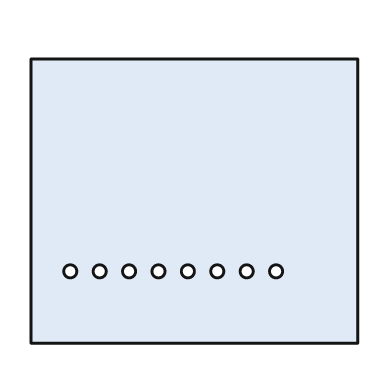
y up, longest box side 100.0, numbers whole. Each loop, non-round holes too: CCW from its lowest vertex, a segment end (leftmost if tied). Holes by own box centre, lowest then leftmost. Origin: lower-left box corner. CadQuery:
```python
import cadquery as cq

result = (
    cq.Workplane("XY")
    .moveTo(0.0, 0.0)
    .lineTo(100.0, 0.0)
    .lineTo(100.0, 87.0)
    .lineTo(0.0, 87.0)
    .close()
    .moveTo(12.0, 22.0)
    .circle(2.0)
    .moveTo(21.0, 22.0)
    .circle(2.0)
    .moveTo(30.0, 22.0)
    .circle(2.0)
    .moveTo(39.0, 22.0)
    .circle(2.0)
    .moveTo(48.0, 22.0)
    .circle(2.0)
    .moveTo(57.0, 22.0)
    .circle(2.0)
    .moveTo(66.0, 22.0)
    .circle(2.0)
    .moveTo(75.0, 22.0)
    .circle(2.0)
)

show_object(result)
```